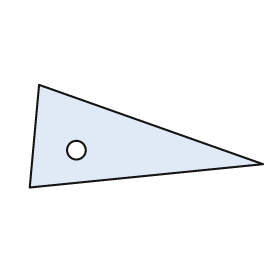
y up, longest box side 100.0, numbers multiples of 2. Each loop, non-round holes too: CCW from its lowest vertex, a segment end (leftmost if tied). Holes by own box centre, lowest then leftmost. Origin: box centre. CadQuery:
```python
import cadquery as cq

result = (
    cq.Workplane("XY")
    .moveTo(-50.0, -22.0)
    .lineTo(50.0, -12.0)
    .lineTo(-46.0, 22.0)
    .close()
    .moveTo(-30.0, -6.0)
    .circle(4.0)
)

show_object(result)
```